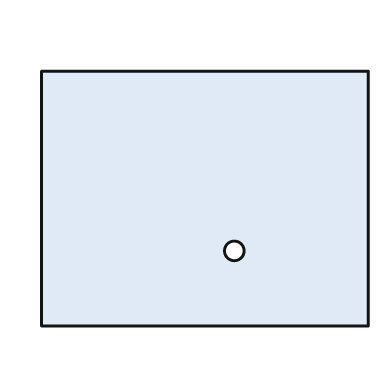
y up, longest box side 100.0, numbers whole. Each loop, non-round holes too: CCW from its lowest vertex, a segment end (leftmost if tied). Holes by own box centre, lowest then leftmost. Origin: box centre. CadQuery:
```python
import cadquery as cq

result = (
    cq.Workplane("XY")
    .moveTo(-50.0, -39.0)
    .lineTo(50.0, -39.0)
    .lineTo(50.0, 39.0)
    .lineTo(-50.0, 39.0)
    .close()
    .moveTo(9.0, -16.0)
    .circle(3.0)
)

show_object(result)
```